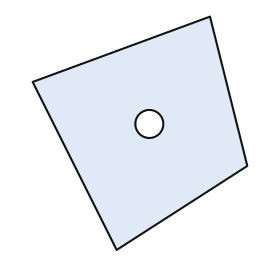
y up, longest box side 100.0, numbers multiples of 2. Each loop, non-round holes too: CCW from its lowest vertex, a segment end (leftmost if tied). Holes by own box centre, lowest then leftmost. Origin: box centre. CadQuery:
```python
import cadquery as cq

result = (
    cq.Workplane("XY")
    .moveTo(-10.0, -50.0)
    .lineTo(46.0, -14.0)
    .lineTo(30.0, 50.0)
    .lineTo(-46.0, 22.0)
    .close()
    .moveTo(4.0, 4.0)
    .circle(6.0)
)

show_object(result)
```